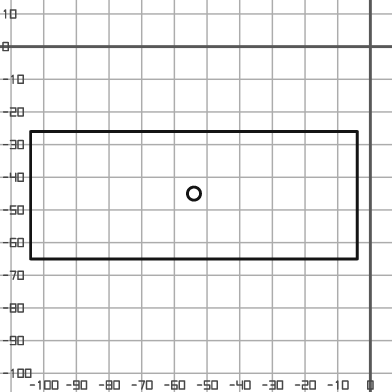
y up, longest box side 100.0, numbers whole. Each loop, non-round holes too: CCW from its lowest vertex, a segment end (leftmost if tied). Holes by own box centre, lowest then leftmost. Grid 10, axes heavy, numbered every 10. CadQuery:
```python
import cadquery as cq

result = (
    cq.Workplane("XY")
    .moveTo(-104.0, -65.0)
    .lineTo(-4.0, -65.0)
    .lineTo(-4.0, -26.0)
    .lineTo(-104.0, -26.0)
    .close()
    .moveTo(-54.0, -45.0)
    .circle(2.0)
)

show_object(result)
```